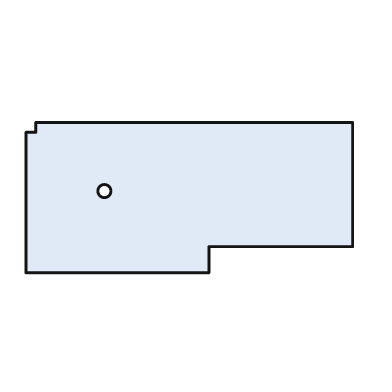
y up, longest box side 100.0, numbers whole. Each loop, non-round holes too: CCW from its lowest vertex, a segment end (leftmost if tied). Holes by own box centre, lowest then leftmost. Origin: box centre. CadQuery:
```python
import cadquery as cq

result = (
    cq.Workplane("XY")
    .moveTo(-50.0, -23.0)
    .lineTo(6.0, -23.0)
    .lineTo(6.0, -15.0)
    .lineTo(50.0, -15.0)
    .lineTo(50.0, 23.0)
    .lineTo(-47.0, 23.0)
    .lineTo(-47.0, 20.0)
    .lineTo(-50.0, 20.0)
    .close()
    .moveTo(-26.0, 2.0)
    .circle(2.0)
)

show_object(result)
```